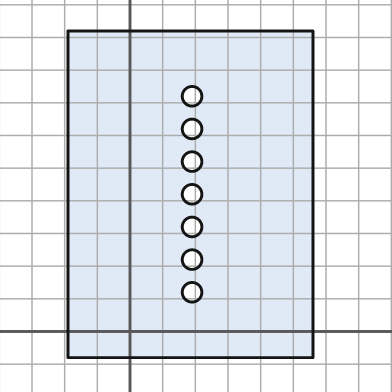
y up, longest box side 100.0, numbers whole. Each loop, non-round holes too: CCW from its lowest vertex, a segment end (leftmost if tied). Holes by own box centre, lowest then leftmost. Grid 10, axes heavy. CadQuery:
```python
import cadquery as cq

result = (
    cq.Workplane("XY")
    .moveTo(-19.0, -8.0)
    .lineTo(56.0, -8.0)
    .lineTo(56.0, 92.0)
    .lineTo(-19.0, 92.0)
    .close()
    .moveTo(19.0, 12.0)
    .circle(3.0)
    .moveTo(19.0, 22.0)
    .circle(3.0)
    .moveTo(19.0, 32.0)
    .circle(3.0)
    .moveTo(19.0, 42.0)
    .circle(3.0)
    .moveTo(19.0, 52.0)
    .circle(3.0)
    .moveTo(19.0, 62.0)
    .circle(3.0)
    .moveTo(19.0, 72.0)
    .circle(3.0)
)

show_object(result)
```